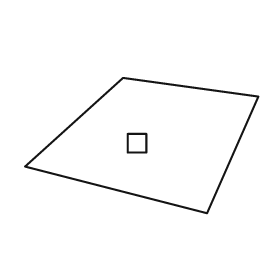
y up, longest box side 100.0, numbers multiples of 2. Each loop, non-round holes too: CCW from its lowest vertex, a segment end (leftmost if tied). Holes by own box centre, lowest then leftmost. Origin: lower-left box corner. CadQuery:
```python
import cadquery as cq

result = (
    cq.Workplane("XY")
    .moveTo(78.0, 0.0)
    .lineTo(100.0, 50.0)
    .lineTo(42.0, 58.0)
    .lineTo(0.0, 20.0)
    .close()
    .moveTo(44.0, 26.0)
    .lineTo(52.0, 26.0)
    .lineTo(52.0, 34.0)
    .lineTo(44.0, 34.0)
    .close()
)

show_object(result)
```